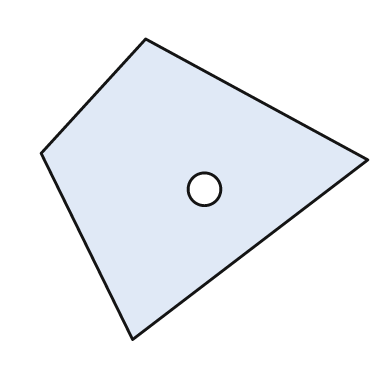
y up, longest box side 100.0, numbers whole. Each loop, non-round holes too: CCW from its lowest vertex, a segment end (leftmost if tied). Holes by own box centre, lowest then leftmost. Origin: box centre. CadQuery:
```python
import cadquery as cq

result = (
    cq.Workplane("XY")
    .moveTo(-22.0, -46.0)
    .lineTo(50.0, 9.0)
    .lineTo(-18.0, 46.0)
    .lineTo(-50.0, 11.0)
    .close()
    .moveTo(0.0, 0.0)
    .circle(5.0)
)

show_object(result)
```